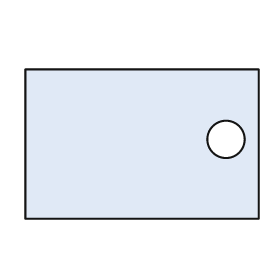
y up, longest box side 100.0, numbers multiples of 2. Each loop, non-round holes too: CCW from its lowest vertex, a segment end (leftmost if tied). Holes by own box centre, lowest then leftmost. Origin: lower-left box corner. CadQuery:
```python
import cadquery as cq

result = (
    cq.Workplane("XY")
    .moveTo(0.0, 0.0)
    .lineTo(100.0, 0.0)
    .lineTo(100.0, 64.0)
    .lineTo(0.0, 64.0)
    .close()
    .moveTo(86.0, 34.0)
    .circle(8.0)
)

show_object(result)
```